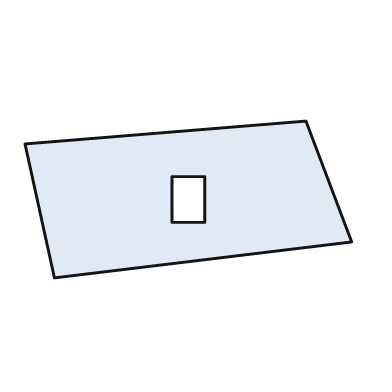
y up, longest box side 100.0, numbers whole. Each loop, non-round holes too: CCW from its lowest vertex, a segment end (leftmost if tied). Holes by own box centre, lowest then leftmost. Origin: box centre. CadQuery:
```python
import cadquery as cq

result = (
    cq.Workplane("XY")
    .moveTo(-41.0, -24.0)
    .lineTo(50.0, -13.0)
    .lineTo(36.0, 24.0)
    .lineTo(-50.0, 17.0)
    .close()
    .moveTo(-5.0, -7.0)
    .lineTo(5.0, -7.0)
    .lineTo(5.0, 7.0)
    .lineTo(-5.0, 7.0)
    .close()
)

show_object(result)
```